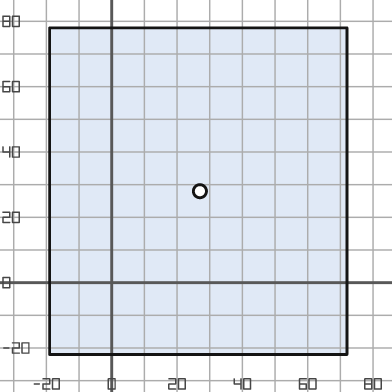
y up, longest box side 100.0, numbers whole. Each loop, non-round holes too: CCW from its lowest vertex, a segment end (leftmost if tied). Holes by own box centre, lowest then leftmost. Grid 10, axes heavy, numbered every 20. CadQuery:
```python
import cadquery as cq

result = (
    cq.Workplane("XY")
    .moveTo(-19.0, -22.0)
    .lineTo(72.0, -22.0)
    .lineTo(72.0, 78.0)
    .lineTo(-19.0, 78.0)
    .close()
    .moveTo(27.0, 28.0)
    .circle(2.0)
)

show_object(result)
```